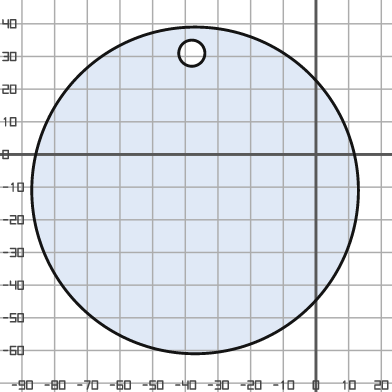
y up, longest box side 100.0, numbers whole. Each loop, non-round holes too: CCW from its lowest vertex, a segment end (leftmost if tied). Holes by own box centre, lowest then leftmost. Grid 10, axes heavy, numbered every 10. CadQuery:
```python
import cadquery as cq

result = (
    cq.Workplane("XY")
    .moveTo(-37.0, -11.0)
    .circle(50.0)
    .moveTo(-38.0, 31.0)
    .circle(4.0)
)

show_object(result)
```